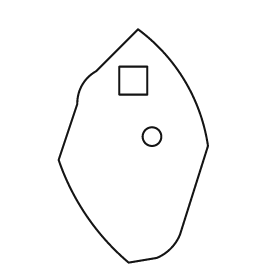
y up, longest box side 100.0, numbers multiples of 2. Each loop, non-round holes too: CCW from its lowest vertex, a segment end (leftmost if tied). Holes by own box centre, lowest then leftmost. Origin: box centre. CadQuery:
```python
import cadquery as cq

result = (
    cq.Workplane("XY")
    .moveTo(-2.0, -50.0)
    .lineTo(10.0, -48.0)
    .threePointArc((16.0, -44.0), (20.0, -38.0))
    .lineTo(32.0, 0.0)
    .threePointArc((22.0, 28.0), (2.0, 50.0))
    .lineTo(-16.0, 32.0)
    .threePointArc((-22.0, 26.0), (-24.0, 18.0))
    .lineTo(-32.0, -6.0)
    .threePointArc((-20.0, -30.0), (-2.0, -50.0))
    .close()
    .moveTo(8.0, 4.0)
    .circle(4.0)
    .moveTo(-6.0, 22.0)
    .lineTo(6.0, 22.0)
    .lineTo(6.0, 34.0)
    .lineTo(-6.0, 34.0)
    .close()
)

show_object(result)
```